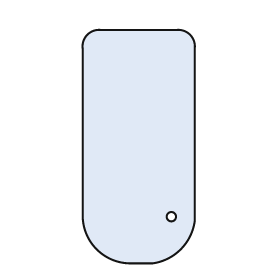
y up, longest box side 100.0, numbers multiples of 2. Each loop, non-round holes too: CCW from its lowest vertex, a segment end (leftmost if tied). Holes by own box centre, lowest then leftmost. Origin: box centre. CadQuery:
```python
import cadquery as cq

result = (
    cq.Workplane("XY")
    .moveTo(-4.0, -50.0)
    .lineTo(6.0, -50.0)
    .threePointArc((18.0, -44.0), (24.0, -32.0))
    .lineTo(24.0, 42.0)
    .threePointArc((22.0, 48.0), (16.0, 50.0))
    .lineTo(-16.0, 50.0)
    .threePointArc((-22.0, 48.0), (-24.0, 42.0))
    .lineTo(-24.0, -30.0)
    .threePointArc((-18.0, -44.0), (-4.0, -50.0))
    .close()
    .moveTo(14.0, -30.0)
    .circle(2.0)
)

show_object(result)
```